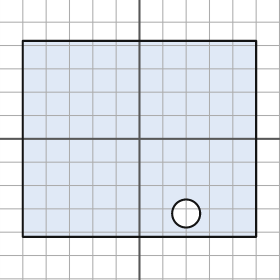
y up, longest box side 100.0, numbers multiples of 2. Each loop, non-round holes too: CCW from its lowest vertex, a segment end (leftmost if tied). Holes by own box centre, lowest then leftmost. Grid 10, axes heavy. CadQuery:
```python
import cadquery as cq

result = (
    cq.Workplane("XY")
    .moveTo(-50.0, -42.0)
    .lineTo(50.0, -42.0)
    .lineTo(50.0, 42.0)
    .lineTo(-50.0, 42.0)
    .close()
    .moveTo(20.0, -32.0)
    .circle(6.0)
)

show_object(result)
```